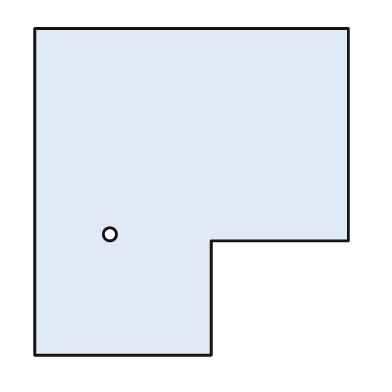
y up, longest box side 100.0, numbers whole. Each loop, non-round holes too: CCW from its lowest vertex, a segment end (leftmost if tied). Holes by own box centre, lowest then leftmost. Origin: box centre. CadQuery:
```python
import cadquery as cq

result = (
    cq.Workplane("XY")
    .moveTo(-48.0, -50.0)
    .lineTo(6.0, -50.0)
    .lineTo(6.0, -15.0)
    .lineTo(48.0, -15.0)
    .lineTo(48.0, 50.0)
    .lineTo(-48.0, 50.0)
    .close()
    .moveTo(-25.0, -13.0)
    .circle(2.0)
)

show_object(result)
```